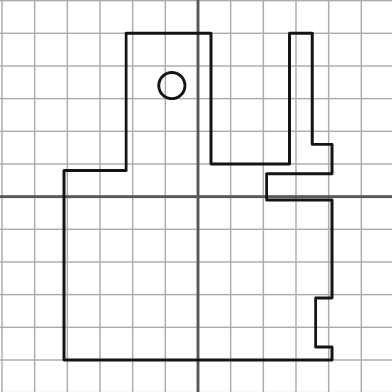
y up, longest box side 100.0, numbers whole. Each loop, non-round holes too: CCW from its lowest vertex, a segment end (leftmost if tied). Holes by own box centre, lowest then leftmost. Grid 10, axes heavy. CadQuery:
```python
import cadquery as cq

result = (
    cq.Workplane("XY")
    .moveTo(-41.0, -50.0)
    .lineTo(41.0, -50.0)
    .lineTo(41.0, -46.0)
    .lineTo(36.0, -46.0)
    .lineTo(36.0, -31.0)
    .lineTo(41.0, -31.0)
    .lineTo(41.0, -1.0)
    .lineTo(21.0, -1.0)
    .lineTo(21.0, 7.0)
    .lineTo(41.0, 7.0)
    .lineTo(41.0, 16.0)
    .lineTo(35.0, 16.0)
    .lineTo(35.0, 50.0)
    .lineTo(28.0, 50.0)
    .lineTo(28.0, 10.0)
    .lineTo(4.0, 10.0)
    .lineTo(4.0, 50.0)
    .lineTo(-22.0, 50.0)
    .lineTo(-22.0, 8.0)
    .lineTo(-41.0, 8.0)
    .close()
    .moveTo(-8.0, 34.0)
    .circle(4.0)
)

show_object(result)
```